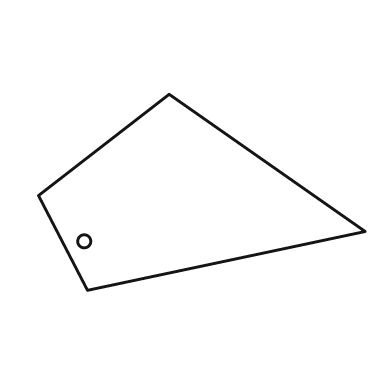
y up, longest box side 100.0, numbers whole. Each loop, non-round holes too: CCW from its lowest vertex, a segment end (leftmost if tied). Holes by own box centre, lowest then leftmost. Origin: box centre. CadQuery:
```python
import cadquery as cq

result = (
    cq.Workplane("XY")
    .moveTo(-35.0, -30.0)
    .lineTo(50.0, -12.0)
    .lineTo(-10.0, 30.0)
    .lineTo(-50.0, -1.0)
    .close()
    .moveTo(-36.0, -15.0)
    .circle(2.0)
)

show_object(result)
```